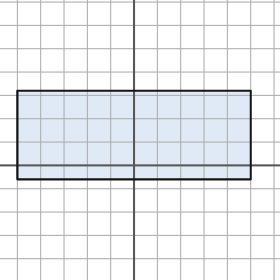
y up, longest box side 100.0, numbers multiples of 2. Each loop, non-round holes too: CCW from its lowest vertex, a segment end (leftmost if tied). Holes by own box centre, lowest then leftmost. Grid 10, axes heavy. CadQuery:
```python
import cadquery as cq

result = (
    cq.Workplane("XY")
    .moveTo(-50.0, -6.0)
    .lineTo(50.0, -6.0)
    .lineTo(50.0, 32.0)
    .lineTo(-50.0, 32.0)
    .close()
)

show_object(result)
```